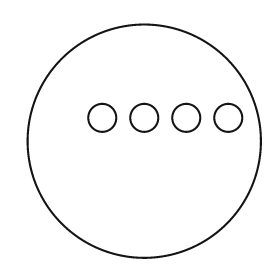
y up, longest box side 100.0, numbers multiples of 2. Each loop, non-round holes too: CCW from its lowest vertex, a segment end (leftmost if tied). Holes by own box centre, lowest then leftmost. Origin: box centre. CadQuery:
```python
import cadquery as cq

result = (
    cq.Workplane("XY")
    .moveTo(0.0, 0.0)
    .circle(50.0)
    .moveTo(-18.0, 10.0)
    .circle(6.0)
    .moveTo(0.0, 10.0)
    .circle(6.0)
    .moveTo(18.0, 10.0)
    .circle(6.0)
    .moveTo(36.0, 10.0)
    .circle(6.0)
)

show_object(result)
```